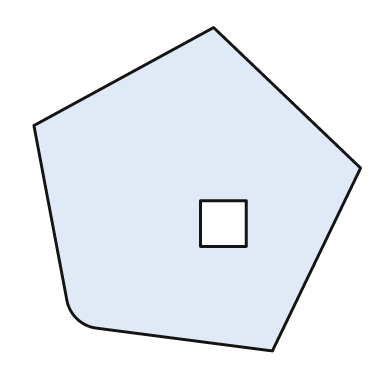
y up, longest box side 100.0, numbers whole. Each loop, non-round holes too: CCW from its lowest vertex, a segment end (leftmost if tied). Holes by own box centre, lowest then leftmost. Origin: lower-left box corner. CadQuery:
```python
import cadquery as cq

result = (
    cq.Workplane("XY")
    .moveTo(73.0, 0.0)
    .lineTo(100.0, 56.0)
    .lineTo(55.0, 99.0)
    .lineTo(0.0, 69.0)
    .lineTo(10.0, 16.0)
    .threePointArc((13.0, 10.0), (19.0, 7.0))
    .close()
    .moveTo(51.0, 32.0)
    .lineTo(65.0, 32.0)
    .lineTo(65.0, 46.0)
    .lineTo(51.0, 46.0)
    .close()
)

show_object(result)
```